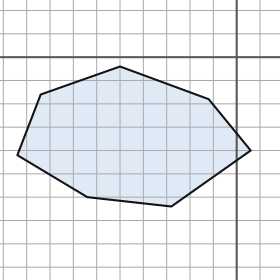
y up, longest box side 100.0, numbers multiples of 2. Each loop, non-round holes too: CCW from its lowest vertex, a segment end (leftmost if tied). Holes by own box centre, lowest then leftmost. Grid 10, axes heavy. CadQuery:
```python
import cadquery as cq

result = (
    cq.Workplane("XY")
    .moveTo(-28.0, -64.0)
    .lineTo(6.0, -40.0)
    .lineTo(-12.0, -18.0)
    .lineTo(-50.0, -4.0)
    .lineTo(-84.0, -16.0)
    .lineTo(-94.0, -42.0)
    .lineTo(-64.0, -60.0)
    .close()
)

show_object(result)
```